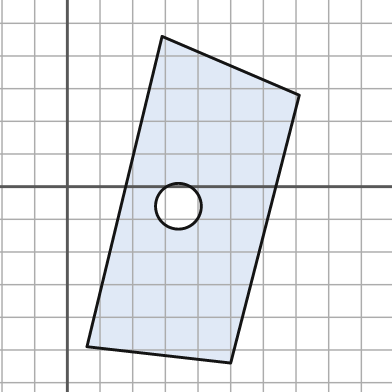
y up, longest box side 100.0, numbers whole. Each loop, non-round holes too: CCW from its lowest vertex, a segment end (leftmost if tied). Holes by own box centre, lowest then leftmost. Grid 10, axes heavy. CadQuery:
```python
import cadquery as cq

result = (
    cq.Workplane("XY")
    .moveTo(50.0, -54.0)
    .lineTo(71.0, 28.0)
    .lineTo(29.0, 46.0)
    .lineTo(6.0, -49.0)
    .close()
    .moveTo(34.0, -6.0)
    .circle(7.0)
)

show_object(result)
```